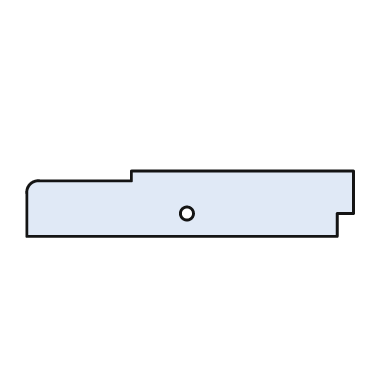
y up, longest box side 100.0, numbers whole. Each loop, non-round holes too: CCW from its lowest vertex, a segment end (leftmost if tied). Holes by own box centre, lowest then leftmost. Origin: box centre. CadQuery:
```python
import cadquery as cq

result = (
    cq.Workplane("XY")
    .moveTo(-50.0, -10.0)
    .lineTo(45.0, -10.0)
    .lineTo(45.0, -3.0)
    .lineTo(50.0, -3.0)
    .lineTo(50.0, 10.0)
    .lineTo(-18.0, 10.0)
    .lineTo(-18.0, 7.0)
    .lineTo(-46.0, 7.0)
    .threePointArc((-49.0, 6.0), (-50.0, 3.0))
    .close()
    .moveTo(-1.0, -3.0)
    .circle(2.0)
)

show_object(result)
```